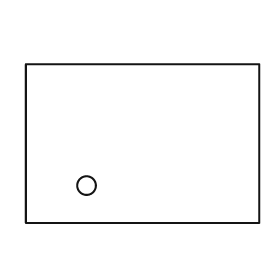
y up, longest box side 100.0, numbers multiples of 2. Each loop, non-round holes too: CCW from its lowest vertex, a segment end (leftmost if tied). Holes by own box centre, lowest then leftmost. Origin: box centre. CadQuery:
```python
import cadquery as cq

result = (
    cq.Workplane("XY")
    .moveTo(-50.0, -34.0)
    .lineTo(50.0, -34.0)
    .lineTo(50.0, 34.0)
    .lineTo(-50.0, 34.0)
    .close()
    .moveTo(-24.0, -18.0)
    .circle(4.0)
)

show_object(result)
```